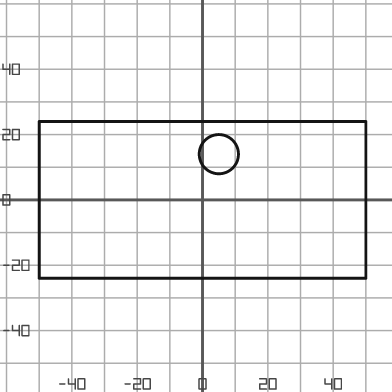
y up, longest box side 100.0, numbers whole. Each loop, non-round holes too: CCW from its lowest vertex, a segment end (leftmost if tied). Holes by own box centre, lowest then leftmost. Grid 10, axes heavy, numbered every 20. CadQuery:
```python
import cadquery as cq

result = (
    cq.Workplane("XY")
    .moveTo(-50.0, -24.0)
    .lineTo(50.0, -24.0)
    .lineTo(50.0, 24.0)
    .lineTo(-50.0, 24.0)
    .close()
    .moveTo(5.0, 14.0)
    .circle(6.0)
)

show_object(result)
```